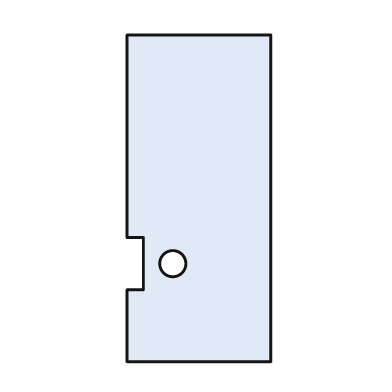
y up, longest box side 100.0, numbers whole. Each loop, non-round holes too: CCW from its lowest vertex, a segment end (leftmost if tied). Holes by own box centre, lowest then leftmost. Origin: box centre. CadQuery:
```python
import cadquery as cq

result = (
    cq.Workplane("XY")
    .moveTo(-22.0, -50.0)
    .lineTo(22.0, -50.0)
    .lineTo(22.0, 50.0)
    .lineTo(-22.0, 50.0)
    .lineTo(-22.0, -12.0)
    .lineTo(-17.0, -12.0)
    .lineTo(-17.0, -28.0)
    .lineTo(-22.0, -28.0)
    .close()
    .moveTo(-8.0, -20.0)
    .circle(4.0)
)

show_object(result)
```